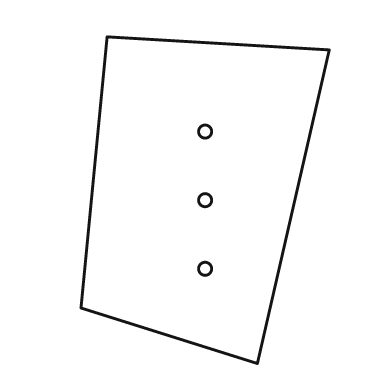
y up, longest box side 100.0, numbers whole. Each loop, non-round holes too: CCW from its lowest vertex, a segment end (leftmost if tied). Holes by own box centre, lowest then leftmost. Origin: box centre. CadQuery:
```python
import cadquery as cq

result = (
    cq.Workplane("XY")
    .moveTo(16.0, -50.0)
    .lineTo(38.0, 46.0)
    .lineTo(-30.0, 50.0)
    .lineTo(-38.0, -33.0)
    .close()
    .moveTo(0.0, -21.0)
    .circle(2.0)
    .moveTo(0.0, 0.0)
    .circle(2.0)
    .moveTo(0.0, 21.0)
    .circle(2.0)
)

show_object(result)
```